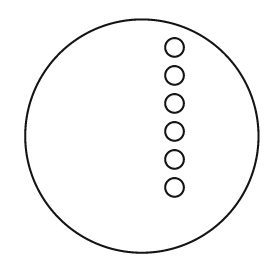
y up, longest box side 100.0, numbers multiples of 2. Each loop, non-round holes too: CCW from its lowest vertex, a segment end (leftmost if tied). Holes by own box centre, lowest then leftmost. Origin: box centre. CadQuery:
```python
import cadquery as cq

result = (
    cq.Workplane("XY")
    .moveTo(0.0, 0.0)
    .circle(50.0)
    .moveTo(14.0, -22.0)
    .circle(4.0)
    .moveTo(14.0, -10.0)
    .circle(4.0)
    .moveTo(14.0, 2.0)
    .circle(4.0)
    .moveTo(14.0, 14.0)
    .circle(4.0)
    .moveTo(14.0, 26.0)
    .circle(4.0)
    .moveTo(14.0, 38.0)
    .circle(4.0)
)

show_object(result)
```